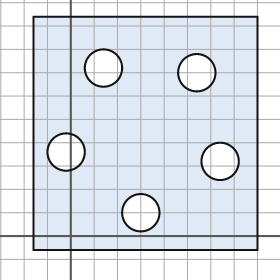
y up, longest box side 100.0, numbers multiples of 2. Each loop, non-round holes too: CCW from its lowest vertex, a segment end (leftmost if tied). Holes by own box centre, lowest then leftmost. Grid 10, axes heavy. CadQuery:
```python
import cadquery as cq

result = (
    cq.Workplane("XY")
    .moveTo(-16.0, -6.0)
    .lineTo(80.0, -6.0)
    .lineTo(80.0, 94.0)
    .lineTo(-16.0, 94.0)
    .close()
    .moveTo(30.0, 10.0)
    .circle(8.0)
    .moveTo(64.0, 32.0)
    .circle(8.0)
    .moveTo(-2.0, 36.0)
    .circle(8.0)
    .moveTo(54.0, 70.0)
    .circle(8.0)
    .moveTo(14.0, 72.0)
    .circle(8.0)
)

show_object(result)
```